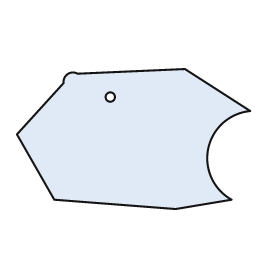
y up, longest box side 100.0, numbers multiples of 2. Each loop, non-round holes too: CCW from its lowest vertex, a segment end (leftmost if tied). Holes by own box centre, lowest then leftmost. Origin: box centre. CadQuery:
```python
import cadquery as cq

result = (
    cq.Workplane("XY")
    .moveTo(18.0, -30.0)
    .lineTo(42.0, -26.0)
    .threePointArc((32.0, -4.0), (50.0, 12.0))
    .lineTo(22.0, 30.0)
    .lineTo(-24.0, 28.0)
    .threePointArc((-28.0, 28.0), (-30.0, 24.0))
    .lineTo(-50.0, 2.0)
    .lineTo(-34.0, -26.0)
    .close()
    .moveTo(-10.0, 18.0)
    .circle(2.0)
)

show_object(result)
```